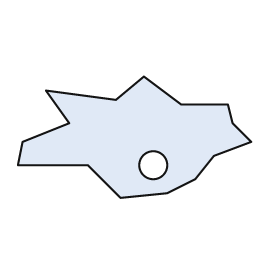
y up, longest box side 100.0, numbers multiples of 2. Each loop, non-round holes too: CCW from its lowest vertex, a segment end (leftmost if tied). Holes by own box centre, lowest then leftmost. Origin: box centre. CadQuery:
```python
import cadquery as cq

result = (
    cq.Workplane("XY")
    .moveTo(-6.0, -26.0)
    .lineTo(14.0, -24.0)
    .lineTo(26.0, -18.0)
    .lineTo(34.0, -8.0)
    .lineTo(50.0, -2.0)
    .lineTo(42.0, 6.0)
    .lineTo(40.0, 14.0)
    .lineTo(20.0, 14.0)
    .lineTo(4.0, 26.0)
    .lineTo(-8.0, 16.0)
    .lineTo(-38.0, 20.0)
    .lineTo(-28.0, 6.0)
    .lineTo(-48.0, -2.0)
    .lineTo(-50.0, -12.0)
    .lineTo(-20.0, -12.0)
    .close()
    .moveTo(8.0, -12.0)
    .circle(6.0)
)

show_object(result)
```